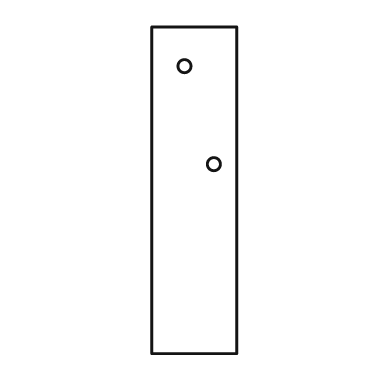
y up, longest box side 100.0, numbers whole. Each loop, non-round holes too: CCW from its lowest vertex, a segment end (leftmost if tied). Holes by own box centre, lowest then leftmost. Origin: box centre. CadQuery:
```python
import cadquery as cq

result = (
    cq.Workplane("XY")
    .moveTo(-13.0, -50.0)
    .lineTo(13.0, -50.0)
    .lineTo(13.0, 50.0)
    .lineTo(-13.0, 50.0)
    .close()
    .moveTo(6.0, 8.0)
    .circle(2.0)
    .moveTo(-3.0, 38.0)
    .circle(2.0)
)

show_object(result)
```